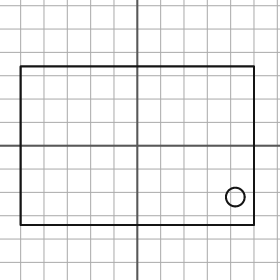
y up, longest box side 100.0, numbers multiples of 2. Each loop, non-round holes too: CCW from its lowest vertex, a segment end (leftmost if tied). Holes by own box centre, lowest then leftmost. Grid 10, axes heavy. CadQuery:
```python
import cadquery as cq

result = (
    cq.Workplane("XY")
    .moveTo(-50.0, -34.0)
    .lineTo(50.0, -34.0)
    .lineTo(50.0, 34.0)
    .lineTo(-50.0, 34.0)
    .close()
    .moveTo(42.0, -22.0)
    .circle(4.0)
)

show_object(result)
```